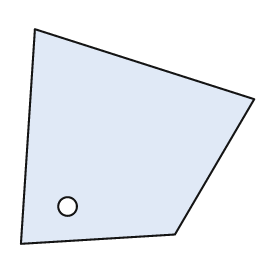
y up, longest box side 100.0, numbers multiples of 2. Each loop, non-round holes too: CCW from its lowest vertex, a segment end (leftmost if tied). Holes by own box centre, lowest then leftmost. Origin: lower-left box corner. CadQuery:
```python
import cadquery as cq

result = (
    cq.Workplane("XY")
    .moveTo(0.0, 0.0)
    .lineTo(66.0, 4.0)
    .lineTo(100.0, 62.0)
    .lineTo(6.0, 92.0)
    .close()
    .moveTo(20.0, 16.0)
    .circle(4.0)
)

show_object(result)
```